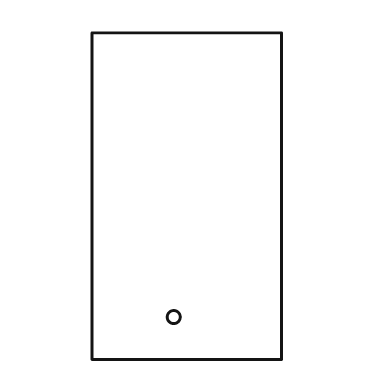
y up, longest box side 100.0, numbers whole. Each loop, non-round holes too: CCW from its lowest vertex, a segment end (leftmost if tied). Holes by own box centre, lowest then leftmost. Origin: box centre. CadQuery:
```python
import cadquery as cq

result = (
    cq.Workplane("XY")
    .moveTo(-29.0, -50.0)
    .lineTo(29.0, -50.0)
    .lineTo(29.0, 50.0)
    .lineTo(-29.0, 50.0)
    .close()
    .moveTo(-4.0, -37.0)
    .circle(2.0)
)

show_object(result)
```